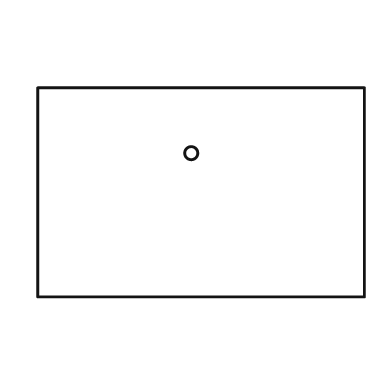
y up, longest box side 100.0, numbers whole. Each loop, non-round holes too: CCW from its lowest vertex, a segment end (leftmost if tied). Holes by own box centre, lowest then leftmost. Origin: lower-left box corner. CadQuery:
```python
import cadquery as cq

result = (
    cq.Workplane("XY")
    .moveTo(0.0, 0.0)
    .lineTo(100.0, 0.0)
    .lineTo(100.0, 64.0)
    .lineTo(0.0, 64.0)
    .close()
    .moveTo(47.0, 44.0)
    .circle(2.0)
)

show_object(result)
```